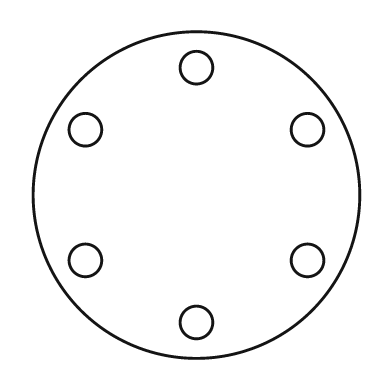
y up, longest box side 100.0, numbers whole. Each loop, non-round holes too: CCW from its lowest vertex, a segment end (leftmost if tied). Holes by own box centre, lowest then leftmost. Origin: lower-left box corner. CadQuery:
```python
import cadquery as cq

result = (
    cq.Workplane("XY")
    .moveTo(50.0, 50.0)
    .circle(50.0)
    .moveTo(50.0, 11.0)
    .circle(5.0)
    .moveTo(16.0, 30.0)
    .circle(5.0)
    .moveTo(84.0, 30.0)
    .circle(5.0)
    .moveTo(16.0, 70.0)
    .circle(5.0)
    .moveTo(84.0, 70.0)
    .circle(5.0)
    .moveTo(50.0, 89.0)
    .circle(5.0)
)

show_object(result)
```